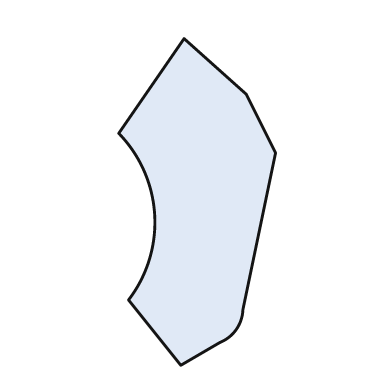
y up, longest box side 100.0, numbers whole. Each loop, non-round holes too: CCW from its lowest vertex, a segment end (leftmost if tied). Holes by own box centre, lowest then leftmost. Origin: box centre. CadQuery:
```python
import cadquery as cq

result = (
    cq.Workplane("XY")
    .moveTo(-5.0, -50.0)
    .lineTo(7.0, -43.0)
    .threePointArc((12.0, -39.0), (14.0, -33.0))
    .lineTo(24.0, 15.0)
    .lineTo(15.0, 33.0)
    .lineTo(-4.0, 50.0)
    .lineTo(-24.0, 21.0)
    .threePointArc((-13.0, -4.0), (-21.0, -30.0))
    .close()
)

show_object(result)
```